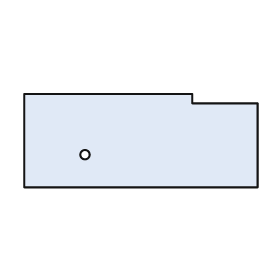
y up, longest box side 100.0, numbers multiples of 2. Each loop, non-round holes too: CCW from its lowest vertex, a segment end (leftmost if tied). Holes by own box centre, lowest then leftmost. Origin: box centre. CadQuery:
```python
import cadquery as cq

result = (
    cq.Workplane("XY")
    .moveTo(-50.0, -20.0)
    .lineTo(50.0, -20.0)
    .lineTo(50.0, 16.0)
    .lineTo(22.0, 16.0)
    .lineTo(22.0, 20.0)
    .lineTo(-50.0, 20.0)
    .close()
    .moveTo(-24.0, -6.0)
    .circle(2.0)
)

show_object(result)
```